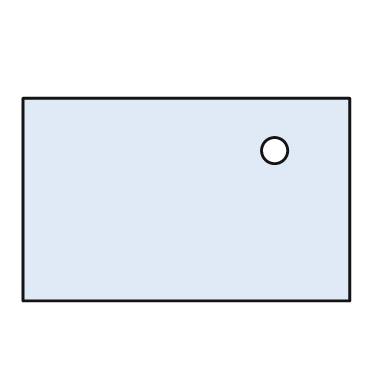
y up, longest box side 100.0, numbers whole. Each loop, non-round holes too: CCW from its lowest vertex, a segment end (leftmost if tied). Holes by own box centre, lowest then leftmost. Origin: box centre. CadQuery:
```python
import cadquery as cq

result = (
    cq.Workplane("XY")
    .moveTo(-50.0, -31.0)
    .lineTo(50.0, -31.0)
    .lineTo(50.0, 31.0)
    .lineTo(-50.0, 31.0)
    .close()
    .moveTo(27.0, 15.0)
    .circle(4.0)
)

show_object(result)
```